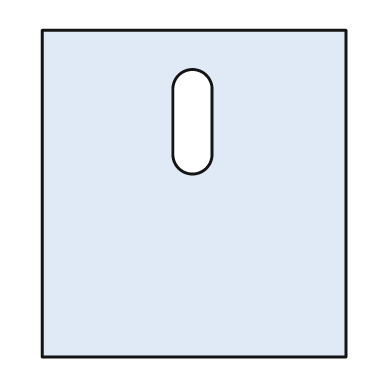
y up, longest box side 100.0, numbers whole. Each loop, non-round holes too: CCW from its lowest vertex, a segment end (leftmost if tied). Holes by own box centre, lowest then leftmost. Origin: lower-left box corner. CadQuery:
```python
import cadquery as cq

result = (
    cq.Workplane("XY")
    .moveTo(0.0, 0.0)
    .lineTo(93.0, 0.0)
    .lineTo(93.0, 100.0)
    .lineTo(0.0, 100.0)
    .close()
    .moveTo(40.0, 62.0)
    .threePointArc((46.0, 56.0), (52.0, 62.0))
    .lineTo(52.0, 82.0)
    .threePointArc((46.0, 88.0), (40.0, 82.0))
    .close()
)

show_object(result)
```